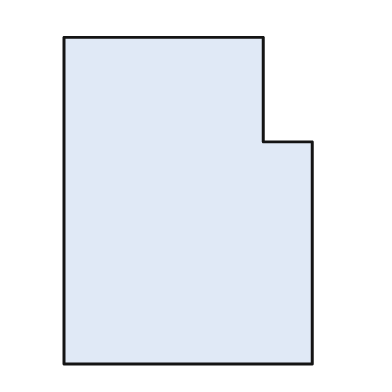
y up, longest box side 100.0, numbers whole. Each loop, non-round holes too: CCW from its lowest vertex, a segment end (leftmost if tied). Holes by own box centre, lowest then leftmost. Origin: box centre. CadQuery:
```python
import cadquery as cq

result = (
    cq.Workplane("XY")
    .moveTo(-38.0, -50.0)
    .lineTo(38.0, -50.0)
    .lineTo(38.0, 18.0)
    .lineTo(23.0, 18.0)
    .lineTo(23.0, 50.0)
    .lineTo(-38.0, 50.0)
    .close()
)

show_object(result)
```